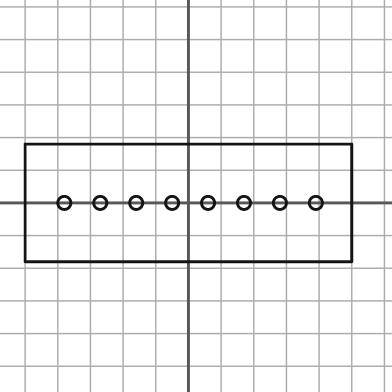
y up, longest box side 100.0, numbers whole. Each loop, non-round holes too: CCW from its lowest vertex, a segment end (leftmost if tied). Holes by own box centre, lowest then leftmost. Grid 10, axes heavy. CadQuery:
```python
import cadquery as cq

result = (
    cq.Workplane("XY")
    .moveTo(-50.0, -18.0)
    .lineTo(50.0, -18.0)
    .lineTo(50.0, 18.0)
    .lineTo(-50.0, 18.0)
    .close()
    .moveTo(-38.0, 0.0)
    .circle(2.0)
    .moveTo(-27.0, 0.0)
    .circle(2.0)
    .moveTo(-16.0, 0.0)
    .circle(2.0)
    .moveTo(-5.0, 0.0)
    .circle(2.0)
    .moveTo(6.0, 0.0)
    .circle(2.0)
    .moveTo(17.0, 0.0)
    .circle(2.0)
    .moveTo(28.0, 0.0)
    .circle(2.0)
    .moveTo(39.0, 0.0)
    .circle(2.0)
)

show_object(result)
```